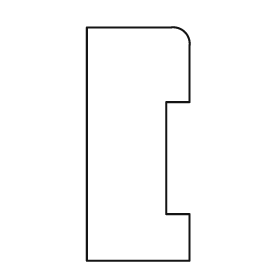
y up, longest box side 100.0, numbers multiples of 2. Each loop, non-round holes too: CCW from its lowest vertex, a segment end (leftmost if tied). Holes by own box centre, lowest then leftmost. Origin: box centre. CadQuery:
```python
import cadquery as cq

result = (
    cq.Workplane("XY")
    .moveTo(-22.0, -50.0)
    .lineTo(22.0, -50.0)
    .lineTo(22.0, -30.0)
    .lineTo(12.0, -30.0)
    .lineTo(12.0, 18.0)
    .lineTo(22.0, 18.0)
    .lineTo(22.0, 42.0)
    .threePointArc((20.0, 48.0), (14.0, 50.0))
    .lineTo(-22.0, 50.0)
    .close()
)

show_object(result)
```